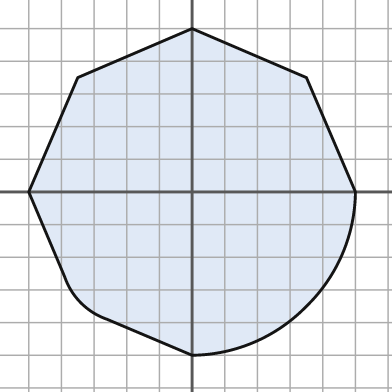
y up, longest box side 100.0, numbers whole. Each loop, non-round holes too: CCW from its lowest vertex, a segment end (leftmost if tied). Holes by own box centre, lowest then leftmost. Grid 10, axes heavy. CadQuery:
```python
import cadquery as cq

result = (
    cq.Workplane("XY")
    .moveTo(0.0, -50.0)
    .threePointArc((19.0, -46.0), (35.0, -35.0))
    .threePointArc((46.0, -19.0), (50.0, 0.0))
    .lineTo(35.0, 35.0)
    .lineTo(0.0, 50.0)
    .lineTo(-35.0, 35.0)
    .lineTo(-50.0, 0.0)
    .lineTo(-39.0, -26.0)
    .threePointArc((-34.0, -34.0), (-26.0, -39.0))
    .close()
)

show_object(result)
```